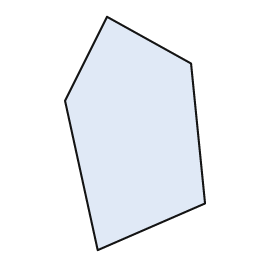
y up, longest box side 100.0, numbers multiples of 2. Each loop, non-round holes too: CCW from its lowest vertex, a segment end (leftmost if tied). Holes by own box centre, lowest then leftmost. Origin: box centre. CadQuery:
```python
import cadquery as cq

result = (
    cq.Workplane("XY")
    .moveTo(-16.0, -50.0)
    .lineTo(30.0, -30.0)
    .lineTo(24.0, 30.0)
    .lineTo(-12.0, 50.0)
    .lineTo(-30.0, 14.0)
    .close()
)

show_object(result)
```